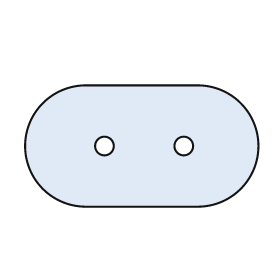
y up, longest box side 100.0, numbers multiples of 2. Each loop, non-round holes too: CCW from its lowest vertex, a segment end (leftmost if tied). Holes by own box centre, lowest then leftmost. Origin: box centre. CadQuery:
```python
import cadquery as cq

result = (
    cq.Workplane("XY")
    .moveTo(-24.0, -26.0)
    .lineTo(24.0, -26.0)
    .threePointArc((50.0, 0.0), (24.0, 26.0))
    .lineTo(-24.0, 26.0)
    .threePointArc((-50.0, 0.0), (-24.0, -26.0))
    .close()
    .moveTo(-16.0, 0.0)
    .circle(4.0)
    .moveTo(18.0, 0.0)
    .circle(4.0)
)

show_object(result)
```